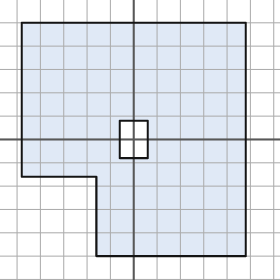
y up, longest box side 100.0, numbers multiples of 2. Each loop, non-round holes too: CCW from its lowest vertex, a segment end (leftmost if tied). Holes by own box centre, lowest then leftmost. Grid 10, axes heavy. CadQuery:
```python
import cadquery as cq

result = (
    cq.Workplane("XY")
    .moveTo(-16.0, -50.0)
    .lineTo(48.0, -50.0)
    .lineTo(48.0, 50.0)
    .lineTo(-48.0, 50.0)
    .lineTo(-48.0, -16.0)
    .lineTo(-16.0, -16.0)
    .close()
    .moveTo(-6.0, -8.0)
    .lineTo(6.0, -8.0)
    .lineTo(6.0, 8.0)
    .lineTo(-6.0, 8.0)
    .close()
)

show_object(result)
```